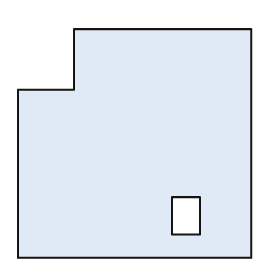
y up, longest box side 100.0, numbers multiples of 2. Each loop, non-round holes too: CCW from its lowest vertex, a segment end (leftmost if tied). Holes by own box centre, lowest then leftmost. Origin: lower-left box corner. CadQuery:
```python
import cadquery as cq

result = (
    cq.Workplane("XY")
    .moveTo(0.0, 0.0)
    .lineTo(100.0, 0.0)
    .lineTo(100.0, 98.0)
    .lineTo(24.0, 98.0)
    .lineTo(24.0, 72.0)
    .lineTo(0.0, 72.0)
    .close()
    .moveTo(66.0, 10.0)
    .lineTo(78.0, 10.0)
    .lineTo(78.0, 26.0)
    .lineTo(66.0, 26.0)
    .close()
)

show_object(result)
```